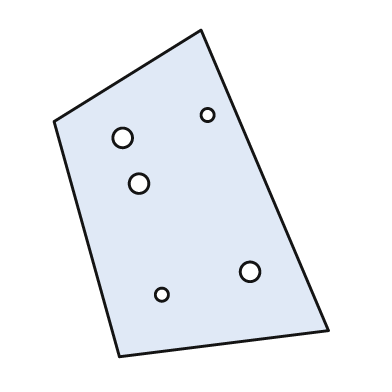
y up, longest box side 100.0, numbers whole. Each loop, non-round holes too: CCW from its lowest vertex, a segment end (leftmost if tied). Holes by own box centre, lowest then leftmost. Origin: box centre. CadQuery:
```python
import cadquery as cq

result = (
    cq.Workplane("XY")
    .moveTo(-22.0, -50.0)
    .lineTo(42.0, -42.0)
    .lineTo(3.0, 50.0)
    .lineTo(-42.0, 22.0)
    .close()
    .moveTo(-9.0, -31.0)
    .circle(2.0)
    .moveTo(18.0, -24.0)
    .circle(3.0)
    .moveTo(-16.0, 3.0)
    .circle(3.0)
    .moveTo(-21.0, 17.0)
    .circle(3.0)
    .moveTo(5.0, 24.0)
    .circle(2.0)
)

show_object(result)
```